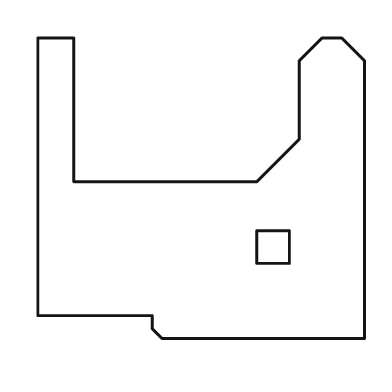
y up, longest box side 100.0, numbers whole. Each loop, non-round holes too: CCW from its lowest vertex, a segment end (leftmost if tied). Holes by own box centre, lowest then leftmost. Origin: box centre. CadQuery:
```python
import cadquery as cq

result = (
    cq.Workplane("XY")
    .moveTo(-12.0, -46.0)
    .lineTo(50.0, -46.0)
    .lineTo(50.0, 39.0)
    .lineTo(43.0, 46.0)
    .lineTo(37.0, 46.0)
    .lineTo(30.0, 39.0)
    .lineTo(30.0, 15.0)
    .lineTo(17.0, 2.0)
    .lineTo(-39.0, 2.0)
    .lineTo(-39.0, 46.0)
    .lineTo(-50.0, 46.0)
    .lineTo(-50.0, -39.0)
    .lineTo(-15.0, -39.0)
    .lineTo(-15.0, -43.0)
    .close()
    .moveTo(17.0, -23.0)
    .lineTo(27.0, -23.0)
    .lineTo(27.0, -13.0)
    .lineTo(17.0, -13.0)
    .close()
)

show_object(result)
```